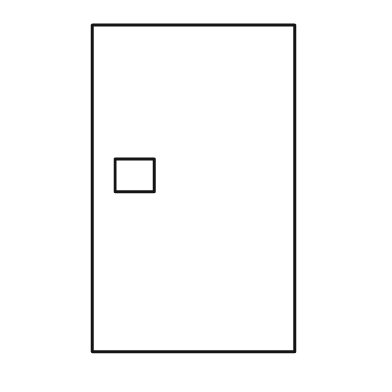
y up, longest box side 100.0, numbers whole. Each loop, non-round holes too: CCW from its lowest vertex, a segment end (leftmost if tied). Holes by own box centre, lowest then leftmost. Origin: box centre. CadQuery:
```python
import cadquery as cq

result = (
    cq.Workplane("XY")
    .moveTo(-31.0, -50.0)
    .lineTo(31.0, -50.0)
    .lineTo(31.0, 50.0)
    .lineTo(-31.0, 50.0)
    .close()
    .moveTo(-24.0, -1.0)
    .lineTo(-12.0, -1.0)
    .lineTo(-12.0, 9.0)
    .lineTo(-24.0, 9.0)
    .close()
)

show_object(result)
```